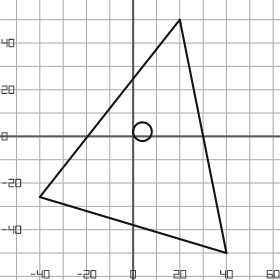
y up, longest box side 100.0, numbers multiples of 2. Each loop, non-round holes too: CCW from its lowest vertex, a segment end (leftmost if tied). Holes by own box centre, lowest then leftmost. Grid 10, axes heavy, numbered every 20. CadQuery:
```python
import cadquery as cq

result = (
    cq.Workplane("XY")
    .moveTo(40.0, -50.0)
    .lineTo(20.0, 50.0)
    .lineTo(-40.0, -26.0)
    .close()
    .moveTo(4.0, 2.0)
    .circle(4.0)
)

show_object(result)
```